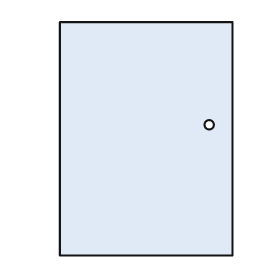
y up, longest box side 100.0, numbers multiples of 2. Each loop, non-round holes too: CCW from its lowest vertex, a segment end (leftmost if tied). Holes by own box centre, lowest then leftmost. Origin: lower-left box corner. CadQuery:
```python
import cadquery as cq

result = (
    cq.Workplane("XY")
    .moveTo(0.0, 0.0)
    .lineTo(74.0, 0.0)
    .lineTo(74.0, 100.0)
    .lineTo(0.0, 100.0)
    .close()
    .moveTo(64.0, 56.0)
    .circle(2.0)
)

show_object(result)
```